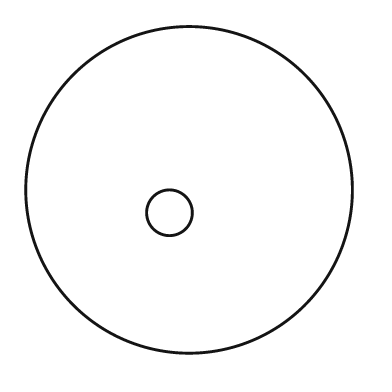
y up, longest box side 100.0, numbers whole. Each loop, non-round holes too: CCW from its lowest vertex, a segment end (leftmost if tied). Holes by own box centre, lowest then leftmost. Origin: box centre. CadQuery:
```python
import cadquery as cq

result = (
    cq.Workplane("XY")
    .moveTo(0.0, 0.0)
    .circle(50.0)
    .moveTo(-6.0, -7.0)
    .circle(7.0)
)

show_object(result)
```